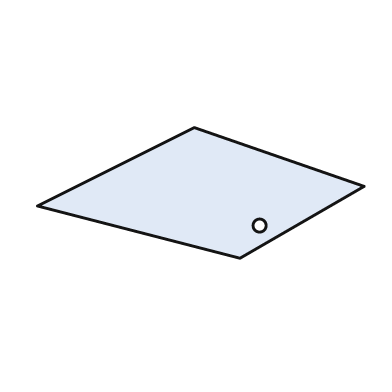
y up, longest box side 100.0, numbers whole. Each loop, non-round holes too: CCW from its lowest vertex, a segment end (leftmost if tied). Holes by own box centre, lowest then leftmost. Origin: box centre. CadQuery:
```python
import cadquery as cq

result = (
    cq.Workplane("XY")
    .moveTo(12.0, -20.0)
    .lineTo(50.0, 2.0)
    .lineTo(-2.0, 20.0)
    .lineTo(-50.0, -4.0)
    .close()
    .moveTo(18.0, -10.0)
    .circle(2.0)
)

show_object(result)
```